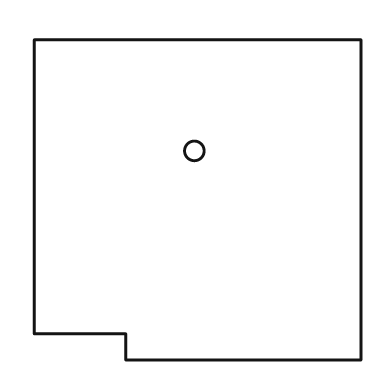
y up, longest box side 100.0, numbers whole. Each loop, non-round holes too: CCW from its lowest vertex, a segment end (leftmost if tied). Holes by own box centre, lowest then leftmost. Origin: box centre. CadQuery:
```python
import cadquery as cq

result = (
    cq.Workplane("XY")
    .moveTo(-22.0, -49.0)
    .lineTo(50.0, -49.0)
    .lineTo(50.0, 49.0)
    .lineTo(-50.0, 49.0)
    .lineTo(-50.0, -41.0)
    .lineTo(-22.0, -41.0)
    .close()
    .moveTo(-1.0, 15.0)
    .circle(3.0)
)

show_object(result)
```